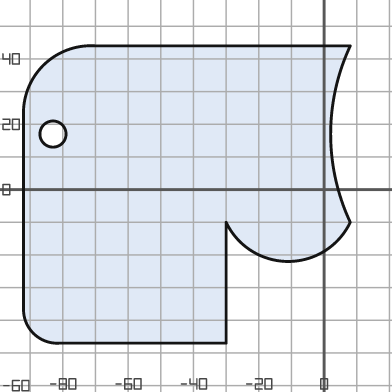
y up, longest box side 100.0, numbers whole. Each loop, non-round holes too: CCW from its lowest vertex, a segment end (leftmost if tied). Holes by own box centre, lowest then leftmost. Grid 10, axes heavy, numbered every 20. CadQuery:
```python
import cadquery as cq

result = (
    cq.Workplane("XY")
    .moveTo(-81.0, -47.0)
    .lineTo(-30.0, -47.0)
    .lineTo(-30.0, -10.0)
    .threePointArc((-11.0, -22.0), (8.0, -10.0))
    .threePointArc((2.0, 17.0), (8.0, 44.0))
    .lineTo(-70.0, 44.0)
    .threePointArc((-86.0, 38.0), (-92.0, 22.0))
    .lineTo(-92.0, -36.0)
    .threePointArc((-89.0, -44.0), (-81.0, -47.0))
    .close()
    .moveTo(-83.0, 17.0)
    .circle(4.0)
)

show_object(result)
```